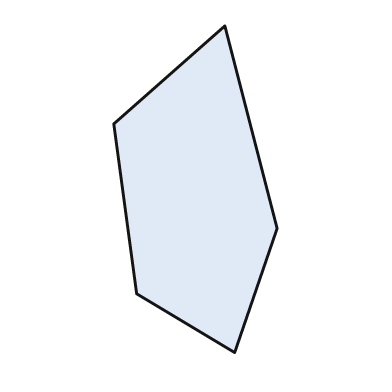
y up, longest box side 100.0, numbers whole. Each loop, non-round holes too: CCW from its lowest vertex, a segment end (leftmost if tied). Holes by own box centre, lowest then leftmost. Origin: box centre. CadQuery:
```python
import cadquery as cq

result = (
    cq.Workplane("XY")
    .moveTo(12.0, -50.0)
    .lineTo(25.0, -12.0)
    .lineTo(9.0, 50.0)
    .lineTo(-25.0, 20.0)
    .lineTo(-18.0, -32.0)
    .close()
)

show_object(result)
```